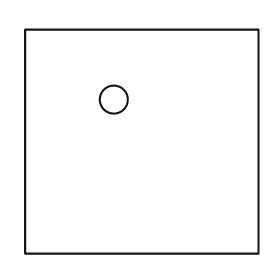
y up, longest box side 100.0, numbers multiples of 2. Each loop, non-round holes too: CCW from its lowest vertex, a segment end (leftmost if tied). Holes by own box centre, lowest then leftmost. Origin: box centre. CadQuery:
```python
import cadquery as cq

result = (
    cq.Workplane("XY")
    .moveTo(-50.0, -48.0)
    .lineTo(50.0, -48.0)
    .lineTo(50.0, 48.0)
    .lineTo(-50.0, 48.0)
    .close()
    .moveTo(-12.0, 18.0)
    .circle(6.0)
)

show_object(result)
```